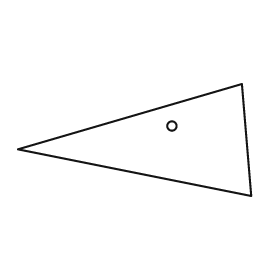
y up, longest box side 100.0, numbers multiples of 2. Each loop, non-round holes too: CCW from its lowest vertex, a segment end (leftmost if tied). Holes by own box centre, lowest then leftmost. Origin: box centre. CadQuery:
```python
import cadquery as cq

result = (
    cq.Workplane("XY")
    .moveTo(50.0, -24.0)
    .lineTo(46.0, 24.0)
    .lineTo(-50.0, -4.0)
    .close()
    .moveTo(16.0, 6.0)
    .circle(2.0)
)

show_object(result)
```